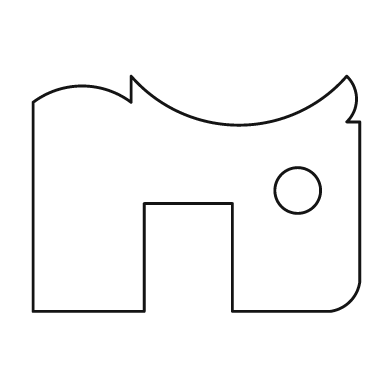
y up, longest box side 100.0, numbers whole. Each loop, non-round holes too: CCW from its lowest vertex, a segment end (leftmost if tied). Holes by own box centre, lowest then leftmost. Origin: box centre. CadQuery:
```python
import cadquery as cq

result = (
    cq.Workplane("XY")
    .moveTo(-50.0, -36.0)
    .lineTo(-16.0, -36.0)
    .lineTo(-16.0, -3.0)
    .lineTo(11.0, -3.0)
    .lineTo(11.0, -36.0)
    .lineTo(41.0, -36.0)
    .threePointArc((47.0, -33.0), (50.0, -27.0))
    .lineTo(50.0, 22.0)
    .lineTo(46.0, 22.0)
    .threePointArc((49.0, 29.0), (46.0, 36.0))
    .threePointArc((13.0, 21.0), (-20.0, 36.0))
    .lineTo(-20.0, 28.0)
    .threePointArc((-35.0, 33.0), (-50.0, 28.0))
    .close()
    .moveTo(31.0, 1.0)
    .circle(7.0)
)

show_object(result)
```